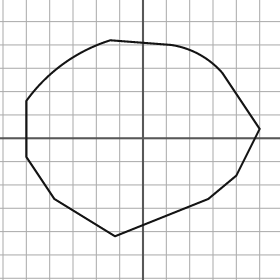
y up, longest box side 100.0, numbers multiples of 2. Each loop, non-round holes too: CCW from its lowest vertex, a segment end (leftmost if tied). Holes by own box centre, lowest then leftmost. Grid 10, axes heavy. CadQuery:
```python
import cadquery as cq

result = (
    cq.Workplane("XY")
    .moveTo(-12.0, -42.0)
    .lineTo(28.0, -26.0)
    .lineTo(40.0, -16.0)
    .lineTo(50.0, 4.0)
    .lineTo(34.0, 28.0)
    .threePointArc((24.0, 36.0), (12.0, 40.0))
    .lineTo(-14.0, 42.0)
    .threePointArc((-34.0, 32.0), (-50.0, 16.0))
    .lineTo(-50.0, -8.0)
    .lineTo(-38.0, -26.0)
    .close()
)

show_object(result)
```